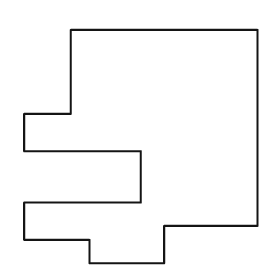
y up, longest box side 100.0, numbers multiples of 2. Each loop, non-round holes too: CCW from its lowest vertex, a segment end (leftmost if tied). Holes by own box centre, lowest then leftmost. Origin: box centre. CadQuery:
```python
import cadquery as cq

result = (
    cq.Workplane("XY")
    .moveTo(-22.0, -50.0)
    .lineTo(10.0, -50.0)
    .lineTo(10.0, -34.0)
    .lineTo(50.0, -34.0)
    .lineTo(50.0, 50.0)
    .lineTo(-30.0, 50.0)
    .lineTo(-30.0, 14.0)
    .lineTo(-50.0, 14.0)
    .lineTo(-50.0, -2.0)
    .lineTo(0.0, -2.0)
    .lineTo(0.0, -24.0)
    .lineTo(-50.0, -24.0)
    .lineTo(-50.0, -40.0)
    .lineTo(-22.0, -40.0)
    .close()
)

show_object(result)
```